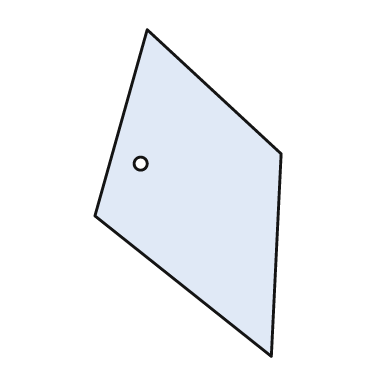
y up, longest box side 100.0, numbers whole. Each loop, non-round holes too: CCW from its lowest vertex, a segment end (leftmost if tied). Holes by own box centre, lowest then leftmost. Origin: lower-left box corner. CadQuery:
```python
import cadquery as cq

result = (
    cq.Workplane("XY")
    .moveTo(54.0, 0.0)
    .lineTo(57.0, 62.0)
    .lineTo(16.0, 100.0)
    .lineTo(0.0, 43.0)
    .close()
    .moveTo(14.0, 59.0)
    .circle(2.0)
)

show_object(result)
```